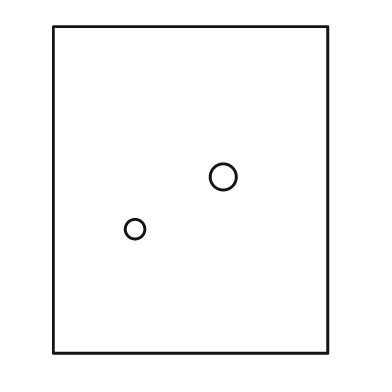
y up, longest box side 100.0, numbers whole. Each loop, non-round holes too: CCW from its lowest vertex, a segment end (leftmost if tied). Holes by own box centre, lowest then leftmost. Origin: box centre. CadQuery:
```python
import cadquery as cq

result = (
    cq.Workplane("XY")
    .moveTo(-42.0, -50.0)
    .lineTo(42.0, -50.0)
    .lineTo(42.0, 50.0)
    .lineTo(-42.0, 50.0)
    .close()
    .moveTo(-17.0, -12.0)
    .circle(3.0)
    .moveTo(10.0, 4.0)
    .circle(4.0)
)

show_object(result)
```